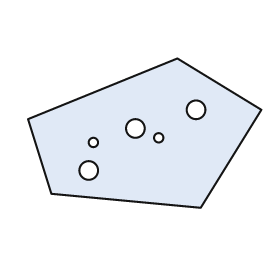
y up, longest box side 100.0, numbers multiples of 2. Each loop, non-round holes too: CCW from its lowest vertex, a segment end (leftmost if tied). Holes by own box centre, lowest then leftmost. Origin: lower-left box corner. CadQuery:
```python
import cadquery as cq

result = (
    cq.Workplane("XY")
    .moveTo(74.0, 0.0)
    .lineTo(100.0, 42.0)
    .lineTo(64.0, 64.0)
    .lineTo(0.0, 38.0)
    .lineTo(10.0, 6.0)
    .close()
    .moveTo(26.0, 16.0)
    .circle(4.0)
    .moveTo(28.0, 28.0)
    .circle(2.0)
    .moveTo(56.0, 30.0)
    .circle(2.0)
    .moveTo(46.0, 34.0)
    .circle(4.0)
    .moveTo(72.0, 42.0)
    .circle(4.0)
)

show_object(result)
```